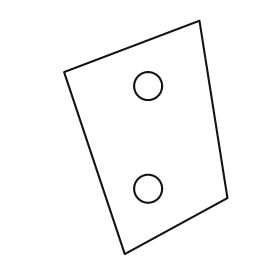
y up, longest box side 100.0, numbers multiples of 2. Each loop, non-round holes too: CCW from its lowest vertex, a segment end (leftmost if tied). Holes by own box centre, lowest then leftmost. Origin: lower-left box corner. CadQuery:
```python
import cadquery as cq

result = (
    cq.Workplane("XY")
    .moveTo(26.0, 0.0)
    .lineTo(70.0, 24.0)
    .lineTo(58.0, 100.0)
    .lineTo(0.0, 78.0)
    .close()
    .moveTo(36.0, 28.0)
    .circle(6.0)
    .moveTo(36.0, 72.0)
    .circle(6.0)
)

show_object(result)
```